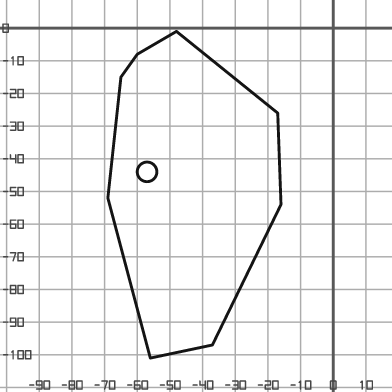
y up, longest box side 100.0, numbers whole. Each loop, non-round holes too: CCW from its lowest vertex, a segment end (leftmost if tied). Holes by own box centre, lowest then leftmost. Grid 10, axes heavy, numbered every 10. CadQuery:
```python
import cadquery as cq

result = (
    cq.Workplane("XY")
    .moveTo(-56.0, -101.0)
    .lineTo(-37.0, -97.0)
    .lineTo(-16.0, -54.0)
    .lineTo(-17.0, -26.0)
    .lineTo(-48.0, -1.0)
    .lineTo(-60.0, -8.0)
    .lineTo(-65.0, -15.0)
    .lineTo(-69.0, -52.0)
    .close()
    .moveTo(-57.0, -44.0)
    .circle(3.0)
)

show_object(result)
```